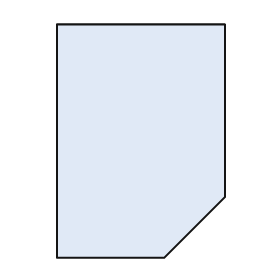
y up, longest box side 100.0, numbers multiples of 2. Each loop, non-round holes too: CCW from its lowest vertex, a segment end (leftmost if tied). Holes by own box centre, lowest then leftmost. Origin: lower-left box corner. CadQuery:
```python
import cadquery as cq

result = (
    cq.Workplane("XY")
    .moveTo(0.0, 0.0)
    .lineTo(46.0, 0.0)
    .lineTo(72.0, 26.0)
    .lineTo(72.0, 100.0)
    .lineTo(0.0, 100.0)
    .close()
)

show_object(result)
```